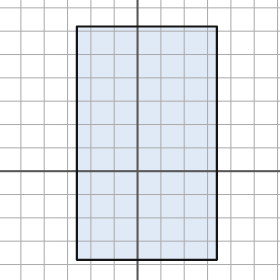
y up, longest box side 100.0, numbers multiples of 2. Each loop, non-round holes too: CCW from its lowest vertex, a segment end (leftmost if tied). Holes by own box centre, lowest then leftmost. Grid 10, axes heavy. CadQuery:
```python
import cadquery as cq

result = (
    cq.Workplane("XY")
    .moveTo(-26.0, -38.0)
    .lineTo(34.0, -38.0)
    .lineTo(34.0, 62.0)
    .lineTo(-26.0, 62.0)
    .close()
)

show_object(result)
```